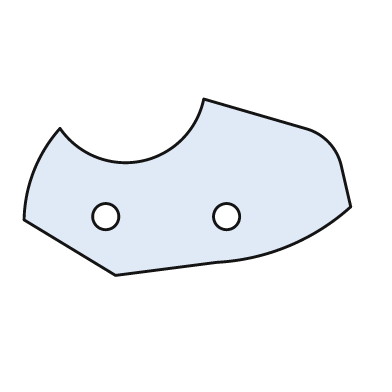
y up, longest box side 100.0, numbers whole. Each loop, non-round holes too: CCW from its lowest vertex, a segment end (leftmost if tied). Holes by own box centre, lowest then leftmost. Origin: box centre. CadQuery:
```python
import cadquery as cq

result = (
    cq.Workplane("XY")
    .moveTo(-22.0, -27.0)
    .lineTo(9.0, -23.0)
    .threePointArc((31.0, -18.0), (50.0, -6.0))
    .lineTo(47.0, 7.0)
    .threePointArc((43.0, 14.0), (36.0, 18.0))
    .lineTo(5.0, 27.0)
    .threePointArc((-14.0, 8.0), (-39.0, 18.0))
    .threePointArc((-47.0, 5.0), (-50.0, -10.0))
    .close()
    .moveTo(-25.0, -9.0)
    .circle(4.0)
    .moveTo(12.0, -9.0)
    .circle(4.0)
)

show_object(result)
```